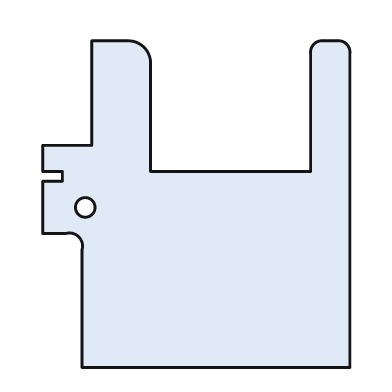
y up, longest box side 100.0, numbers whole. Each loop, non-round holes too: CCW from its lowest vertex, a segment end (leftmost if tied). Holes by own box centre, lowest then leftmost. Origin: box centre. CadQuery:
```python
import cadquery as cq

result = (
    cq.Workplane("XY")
    .moveTo(-35.0, -50.0)
    .lineTo(47.0, -50.0)
    .lineTo(47.0, 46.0)
    .threePointArc((46.0, 49.0), (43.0, 50.0))
    .lineTo(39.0, 50.0)
    .threePointArc((36.0, 49.0), (35.0, 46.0))
    .lineTo(35.0, 10.0)
    .lineTo(-14.0, 10.0)
    .lineTo(-14.0, 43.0)
    .threePointArc((-16.0, 48.0), (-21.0, 50.0))
    .lineTo(-32.0, 50.0)
    .lineTo(-32.0, 18.0)
    .lineTo(-47.0, 18.0)
    .lineTo(-47.0, 10.0)
    .lineTo(-41.0, 10.0)
    .lineTo(-41.0, 7.0)
    .lineTo(-47.0, 7.0)
    .lineTo(-47.0, -9.0)
    .lineTo(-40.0, -9.0)
    .threePointArc((-36.0, -10.0), (-35.0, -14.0))
    .close()
    .moveTo(-34.0, -1.0)
    .circle(3.0)
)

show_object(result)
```